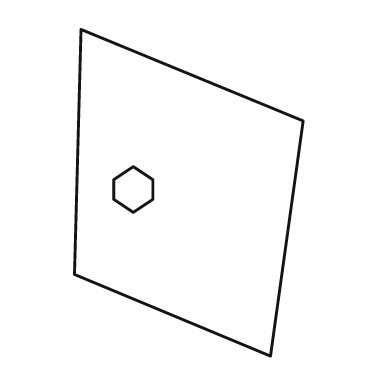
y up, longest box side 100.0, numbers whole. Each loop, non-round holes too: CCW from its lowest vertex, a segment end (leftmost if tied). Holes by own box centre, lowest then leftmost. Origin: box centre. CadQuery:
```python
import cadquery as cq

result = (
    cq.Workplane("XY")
    .moveTo(25.0, -50.0)
    .lineTo(35.0, 22.0)
    .lineTo(-33.0, 50.0)
    .lineTo(-35.0, -25.0)
    .close()
    .moveTo(-17.0, -6.0)
    .lineTo(-11.0, -2.0)
    .lineTo(-11.0, 4.0)
    .lineTo(-17.0, 8.0)
    .lineTo(-23.0, 4.0)
    .lineTo(-23.0, -2.0)
    .close()
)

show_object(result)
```